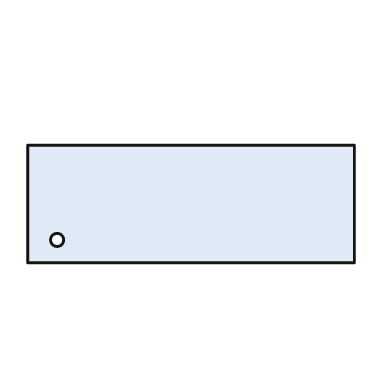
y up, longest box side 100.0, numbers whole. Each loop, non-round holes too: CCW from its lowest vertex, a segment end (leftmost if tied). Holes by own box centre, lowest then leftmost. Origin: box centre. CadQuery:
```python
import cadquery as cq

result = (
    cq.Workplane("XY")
    .moveTo(-50.0, -18.0)
    .lineTo(50.0, -18.0)
    .lineTo(50.0, 18.0)
    .lineTo(-50.0, 18.0)
    .close()
    .moveTo(-41.0, -11.0)
    .circle(2.0)
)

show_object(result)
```